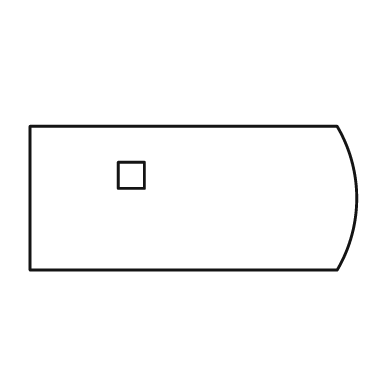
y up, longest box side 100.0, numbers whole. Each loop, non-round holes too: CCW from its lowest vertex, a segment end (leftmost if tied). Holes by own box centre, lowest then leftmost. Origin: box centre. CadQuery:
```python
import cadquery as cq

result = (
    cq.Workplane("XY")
    .moveTo(-50.0, -22.0)
    .lineTo(44.0, -22.0)
    .threePointArc((50.0, 0.0), (44.0, 22.0))
    .lineTo(-50.0, 22.0)
    .close()
    .moveTo(-23.0, 3.0)
    .lineTo(-15.0, 3.0)
    .lineTo(-15.0, 11.0)
    .lineTo(-23.0, 11.0)
    .close()
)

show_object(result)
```